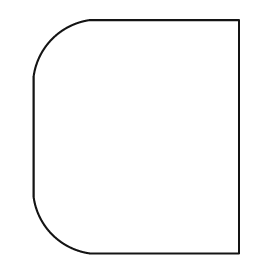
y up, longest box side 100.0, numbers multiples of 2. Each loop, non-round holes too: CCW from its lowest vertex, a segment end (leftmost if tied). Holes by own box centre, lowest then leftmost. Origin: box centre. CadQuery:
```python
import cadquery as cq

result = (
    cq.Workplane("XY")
    .moveTo(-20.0, -50.0)
    .lineTo(44.0, -50.0)
    .lineTo(44.0, 50.0)
    .lineTo(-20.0, 50.0)
    .threePointArc((-36.0, 42.0), (-44.0, 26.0))
    .lineTo(-44.0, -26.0)
    .threePointArc((-36.0, -42.0), (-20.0, -50.0))
    .close()
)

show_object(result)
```